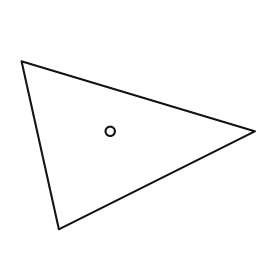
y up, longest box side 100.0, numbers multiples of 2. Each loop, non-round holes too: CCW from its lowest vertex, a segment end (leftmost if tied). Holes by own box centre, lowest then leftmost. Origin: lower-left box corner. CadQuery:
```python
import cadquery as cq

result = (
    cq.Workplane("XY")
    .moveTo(16.0, 0.0)
    .lineTo(100.0, 42.0)
    .lineTo(0.0, 72.0)
    .close()
    .moveTo(38.0, 42.0)
    .circle(2.0)
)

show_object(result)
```